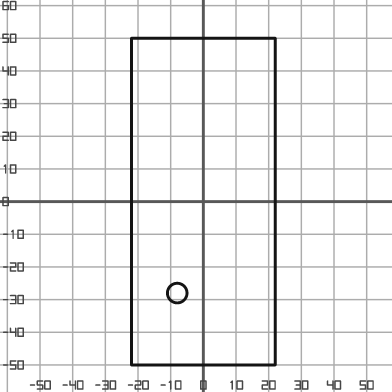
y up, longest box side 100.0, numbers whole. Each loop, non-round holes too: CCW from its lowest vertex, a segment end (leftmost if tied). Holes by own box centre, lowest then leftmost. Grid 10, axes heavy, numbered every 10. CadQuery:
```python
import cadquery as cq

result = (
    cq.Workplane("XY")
    .moveTo(-22.0, -50.0)
    .lineTo(22.0, -50.0)
    .lineTo(22.0, 50.0)
    .lineTo(-22.0, 50.0)
    .close()
    .moveTo(-8.0, -28.0)
    .circle(3.0)
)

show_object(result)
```